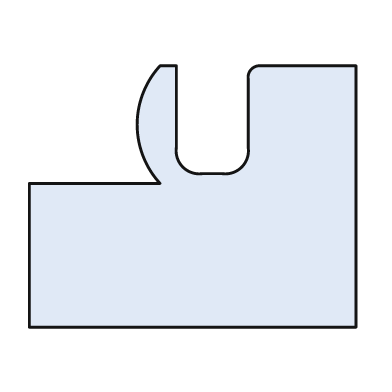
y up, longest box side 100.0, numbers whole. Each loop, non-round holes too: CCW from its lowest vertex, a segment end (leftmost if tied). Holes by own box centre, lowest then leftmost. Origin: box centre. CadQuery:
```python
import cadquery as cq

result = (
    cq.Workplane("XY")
    .moveTo(-50.0, -40.0)
    .lineTo(50.0, -40.0)
    .lineTo(50.0, 40.0)
    .lineTo(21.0, 40.0)
    .threePointArc((18.0, 39.0), (17.0, 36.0))
    .lineTo(17.0, 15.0)
    .threePointArc((15.0, 9.0), (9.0, 7.0))
    .lineTo(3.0, 7.0)
    .threePointArc((-3.0, 9.0), (-5.0, 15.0))
    .lineTo(-5.0, 40.0)
    .lineTo(-10.0, 40.0)
    .threePointArc((-17.0, 22.0), (-10.0, 4.0))
    .lineTo(-50.0, 4.0)
    .close()
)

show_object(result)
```